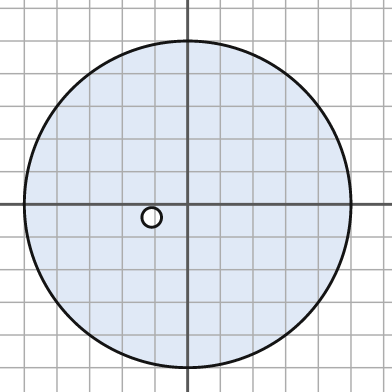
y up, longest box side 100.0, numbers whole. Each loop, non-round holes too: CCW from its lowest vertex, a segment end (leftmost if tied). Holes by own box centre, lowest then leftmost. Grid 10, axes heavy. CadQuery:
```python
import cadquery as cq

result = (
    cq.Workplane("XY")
    .moveTo(0.0, 0.0)
    .circle(50.0)
    .moveTo(-11.0, -4.0)
    .circle(3.0)
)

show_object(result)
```